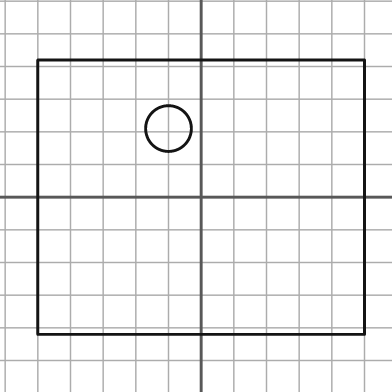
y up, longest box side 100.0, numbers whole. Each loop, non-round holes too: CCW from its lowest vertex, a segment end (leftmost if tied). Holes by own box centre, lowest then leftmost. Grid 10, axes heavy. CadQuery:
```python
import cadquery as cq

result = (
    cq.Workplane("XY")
    .moveTo(-50.0, -42.0)
    .lineTo(50.0, -42.0)
    .lineTo(50.0, 42.0)
    .lineTo(-50.0, 42.0)
    .close()
    .moveTo(-10.0, 21.0)
    .circle(7.0)
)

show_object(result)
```